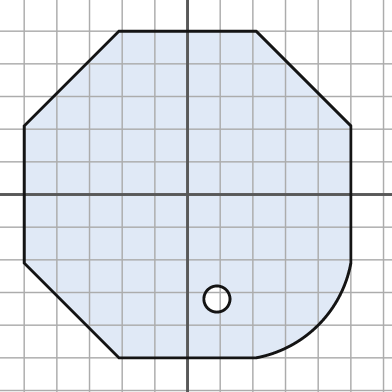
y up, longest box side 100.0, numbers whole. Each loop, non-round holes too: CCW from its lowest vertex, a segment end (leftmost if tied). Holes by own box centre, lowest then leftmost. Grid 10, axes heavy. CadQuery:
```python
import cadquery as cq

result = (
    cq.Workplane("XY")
    .moveTo(-21.0, -50.0)
    .lineTo(21.0, -50.0)
    .threePointArc((40.0, -40.0), (50.0, -21.0))
    .lineTo(50.0, 21.0)
    .lineTo(21.0, 50.0)
    .lineTo(-21.0, 50.0)
    .lineTo(-50.0, 21.0)
    .lineTo(-50.0, -21.0)
    .close()
    .moveTo(9.0, -32.0)
    .circle(4.0)
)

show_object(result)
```